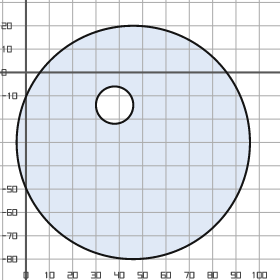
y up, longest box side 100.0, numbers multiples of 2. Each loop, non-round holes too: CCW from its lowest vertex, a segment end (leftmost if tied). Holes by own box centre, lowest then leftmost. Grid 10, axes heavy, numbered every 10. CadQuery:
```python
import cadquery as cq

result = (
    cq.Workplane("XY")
    .moveTo(46.0, -30.0)
    .circle(50.0)
    .moveTo(38.0, -14.0)
    .circle(8.0)
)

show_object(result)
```